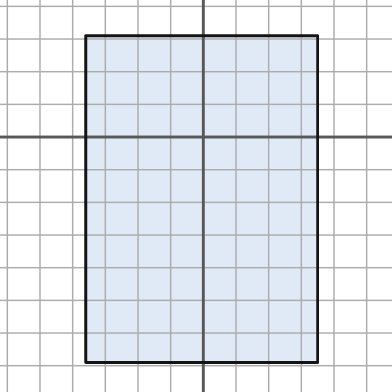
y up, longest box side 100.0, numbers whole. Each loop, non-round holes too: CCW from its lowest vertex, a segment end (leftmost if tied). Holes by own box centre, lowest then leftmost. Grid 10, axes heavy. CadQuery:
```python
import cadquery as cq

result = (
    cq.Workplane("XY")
    .moveTo(-36.0, -69.0)
    .lineTo(35.0, -69.0)
    .lineTo(35.0, 31.0)
    .lineTo(-36.0, 31.0)
    .close()
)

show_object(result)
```